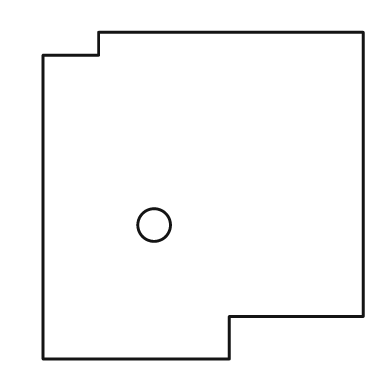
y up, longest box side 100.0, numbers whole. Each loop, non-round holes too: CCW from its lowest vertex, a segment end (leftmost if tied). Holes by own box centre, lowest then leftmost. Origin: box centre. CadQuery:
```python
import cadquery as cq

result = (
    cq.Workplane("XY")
    .moveTo(-49.0, -50.0)
    .lineTo(8.0, -50.0)
    .lineTo(8.0, -37.0)
    .lineTo(49.0, -37.0)
    .lineTo(49.0, 50.0)
    .lineTo(-32.0, 50.0)
    .lineTo(-32.0, 43.0)
    .lineTo(-49.0, 43.0)
    .close()
    .moveTo(-15.0, -9.0)
    .circle(5.0)
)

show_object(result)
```